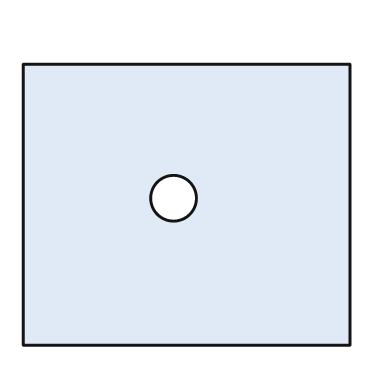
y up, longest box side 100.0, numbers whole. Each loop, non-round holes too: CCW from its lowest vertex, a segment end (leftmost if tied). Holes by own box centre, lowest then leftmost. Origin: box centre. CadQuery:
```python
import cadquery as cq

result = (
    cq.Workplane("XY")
    .moveTo(-50.0, -43.0)
    .lineTo(50.0, -43.0)
    .lineTo(50.0, 43.0)
    .lineTo(-50.0, 43.0)
    .close()
    .moveTo(-4.0, 2.0)
    .circle(7.0)
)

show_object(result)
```